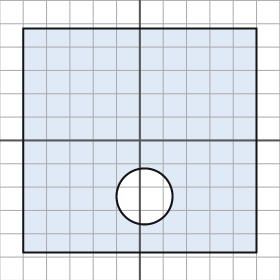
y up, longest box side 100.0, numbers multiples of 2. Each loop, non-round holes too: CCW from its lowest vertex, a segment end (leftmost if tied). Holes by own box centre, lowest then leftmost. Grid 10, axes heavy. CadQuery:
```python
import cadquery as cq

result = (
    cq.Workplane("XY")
    .moveTo(-50.0, -48.0)
    .lineTo(50.0, -48.0)
    .lineTo(50.0, 48.0)
    .lineTo(-50.0, 48.0)
    .close()
    .moveTo(2.0, -24.0)
    .circle(12.0)
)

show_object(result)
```